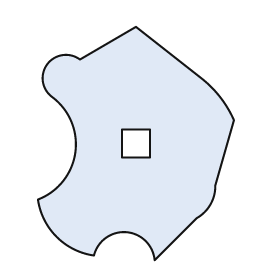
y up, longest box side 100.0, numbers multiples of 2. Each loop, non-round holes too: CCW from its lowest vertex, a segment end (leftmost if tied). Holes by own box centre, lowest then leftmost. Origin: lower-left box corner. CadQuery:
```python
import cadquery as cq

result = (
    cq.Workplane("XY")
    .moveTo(50.0, 0.0)
    .lineTo(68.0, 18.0)
    .threePointArc((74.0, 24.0), (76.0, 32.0))
    .lineTo(84.0, 60.0)
    .threePointArc((78.0, 70.0), (70.0, 78.0))
    .lineTo(42.0, 100.0)
    .lineTo(18.0, 86.0)
    .threePointArc((4.0, 84.0), (6.0, 70.0))
    .threePointArc((16.0, 46.0), (0.0, 26.0))
    .threePointArc((8.0, 10.0), (24.0, 2.0))
    .threePointArc((38.0, 12.0), (50.0, 0.0))
    .close()
    .moveTo(36.0, 44.0)
    .lineTo(48.0, 44.0)
    .lineTo(48.0, 56.0)
    .lineTo(36.0, 56.0)
    .close()
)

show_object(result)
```